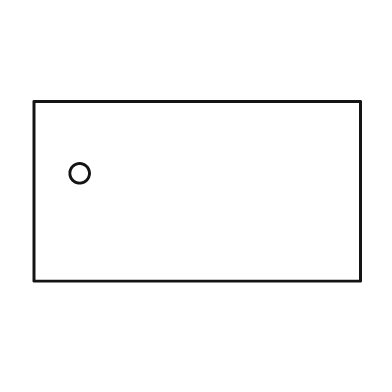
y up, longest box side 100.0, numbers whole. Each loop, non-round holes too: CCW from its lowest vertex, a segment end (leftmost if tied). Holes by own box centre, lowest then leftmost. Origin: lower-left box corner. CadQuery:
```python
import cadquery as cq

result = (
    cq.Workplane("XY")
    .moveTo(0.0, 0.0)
    .lineTo(100.0, 0.0)
    .lineTo(100.0, 55.0)
    .lineTo(0.0, 55.0)
    .close()
    .moveTo(14.0, 33.0)
    .circle(3.0)
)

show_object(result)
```